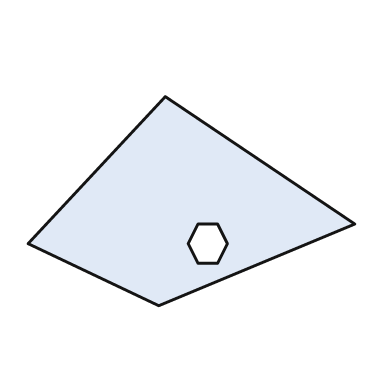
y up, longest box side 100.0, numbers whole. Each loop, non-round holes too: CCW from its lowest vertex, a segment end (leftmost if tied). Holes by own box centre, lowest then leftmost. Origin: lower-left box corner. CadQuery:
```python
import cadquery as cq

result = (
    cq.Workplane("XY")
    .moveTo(40.0, 0.0)
    .lineTo(100.0, 25.0)
    .lineTo(42.0, 64.0)
    .lineTo(0.0, 19.0)
    .close()
    .moveTo(52.0, 13.0)
    .lineTo(58.0, 13.0)
    .lineTo(61.0, 19.0)
    .lineTo(58.0, 25.0)
    .lineTo(52.0, 25.0)
    .lineTo(49.0, 19.0)
    .close()
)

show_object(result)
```